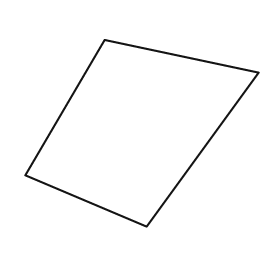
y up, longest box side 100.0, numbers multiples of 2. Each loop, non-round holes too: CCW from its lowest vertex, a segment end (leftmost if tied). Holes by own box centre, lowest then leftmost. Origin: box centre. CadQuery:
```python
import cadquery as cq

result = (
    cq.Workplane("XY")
    .moveTo(2.0, -40.0)
    .lineTo(50.0, 26.0)
    .lineTo(-16.0, 40.0)
    .lineTo(-50.0, -18.0)
    .close()
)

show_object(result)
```